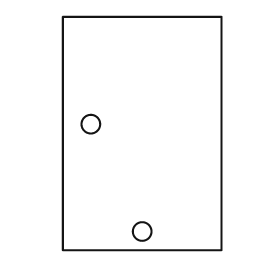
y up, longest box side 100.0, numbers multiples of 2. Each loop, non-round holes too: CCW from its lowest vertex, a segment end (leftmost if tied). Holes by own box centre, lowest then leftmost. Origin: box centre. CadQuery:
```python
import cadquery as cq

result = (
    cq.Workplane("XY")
    .moveTo(-34.0, -50.0)
    .lineTo(34.0, -50.0)
    .lineTo(34.0, 50.0)
    .lineTo(-34.0, 50.0)
    .close()
    .moveTo(0.0, -42.0)
    .circle(4.0)
    .moveTo(-22.0, 4.0)
    .circle(4.0)
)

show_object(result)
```